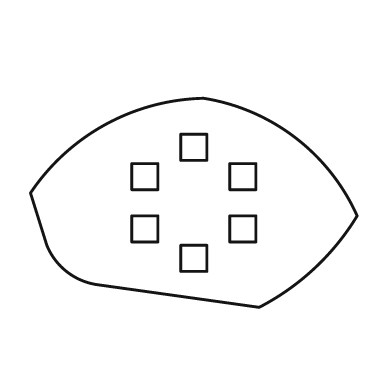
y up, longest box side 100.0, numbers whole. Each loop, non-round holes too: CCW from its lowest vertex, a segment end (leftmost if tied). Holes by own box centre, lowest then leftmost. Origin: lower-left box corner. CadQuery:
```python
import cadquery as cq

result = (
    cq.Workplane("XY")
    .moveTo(70.0, 0.0)
    .threePointArc((87.0, 12.0), (100.0, 28.0))
    .threePointArc((81.0, 52.0), (53.0, 64.0))
    .threePointArc((23.0, 56.0), (0.0, 35.0))
    .lineTo(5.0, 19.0)
    .threePointArc((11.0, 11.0), (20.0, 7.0))
    .close()
    .moveTo(46.0, 11.0)
    .lineTo(54.0, 11.0)
    .lineTo(54.0, 19.0)
    .lineTo(46.0, 19.0)
    .close()
    .moveTo(31.0, 20.0)
    .lineTo(39.0, 20.0)
    .lineTo(39.0, 28.0)
    .lineTo(31.0, 28.0)
    .close()
    .moveTo(61.0, 20.0)
    .lineTo(69.0, 20.0)
    .lineTo(69.0, 28.0)
    .lineTo(61.0, 28.0)
    .close()
    .moveTo(31.0, 36.0)
    .lineTo(39.0, 36.0)
    .lineTo(39.0, 44.0)
    .lineTo(31.0, 44.0)
    .close()
    .moveTo(61.0, 36.0)
    .lineTo(69.0, 36.0)
    .lineTo(69.0, 44.0)
    .lineTo(61.0, 44.0)
    .close()
    .moveTo(46.0, 45.0)
    .lineTo(54.0, 45.0)
    .lineTo(54.0, 53.0)
    .lineTo(46.0, 53.0)
    .close()
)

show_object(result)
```